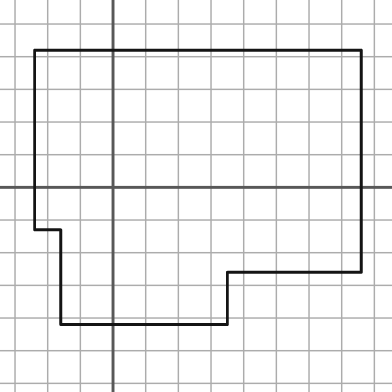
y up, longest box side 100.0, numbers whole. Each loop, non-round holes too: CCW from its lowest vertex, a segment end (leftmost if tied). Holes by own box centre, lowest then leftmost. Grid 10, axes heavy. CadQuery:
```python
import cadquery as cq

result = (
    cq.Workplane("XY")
    .moveTo(-16.0, -42.0)
    .lineTo(35.0, -42.0)
    .lineTo(35.0, -26.0)
    .lineTo(76.0, -26.0)
    .lineTo(76.0, 42.0)
    .lineTo(-24.0, 42.0)
    .lineTo(-24.0, -13.0)
    .lineTo(-16.0, -13.0)
    .close()
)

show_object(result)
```